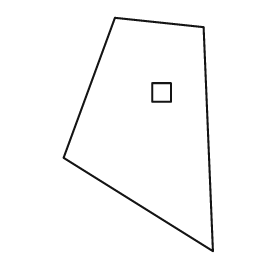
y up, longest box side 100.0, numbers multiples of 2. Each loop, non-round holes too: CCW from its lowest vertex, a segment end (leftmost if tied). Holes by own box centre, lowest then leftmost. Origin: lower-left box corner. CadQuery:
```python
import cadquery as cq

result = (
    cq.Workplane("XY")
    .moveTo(64.0, 0.0)
    .lineTo(60.0, 96.0)
    .lineTo(22.0, 100.0)
    .lineTo(0.0, 40.0)
    .close()
    .moveTo(38.0, 64.0)
    .lineTo(46.0, 64.0)
    .lineTo(46.0, 72.0)
    .lineTo(38.0, 72.0)
    .close()
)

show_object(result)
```